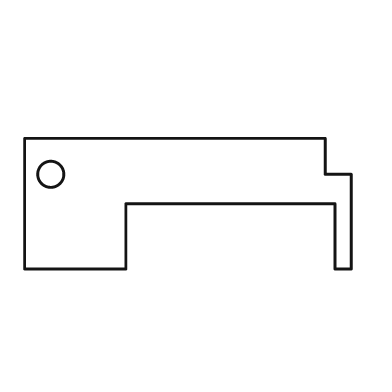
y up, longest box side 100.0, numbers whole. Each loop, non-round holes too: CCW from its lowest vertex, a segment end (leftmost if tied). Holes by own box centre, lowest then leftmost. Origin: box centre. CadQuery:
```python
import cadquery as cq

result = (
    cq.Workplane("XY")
    .moveTo(-50.0, -20.0)
    .lineTo(-19.0, -20.0)
    .lineTo(-19.0, 0.0)
    .lineTo(45.0, 0.0)
    .lineTo(45.0, -20.0)
    .lineTo(50.0, -20.0)
    .lineTo(50.0, 9.0)
    .lineTo(42.0, 9.0)
    .lineTo(42.0, 20.0)
    .lineTo(-50.0, 20.0)
    .close()
    .moveTo(-42.0, 9.0)
    .circle(4.0)
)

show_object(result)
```